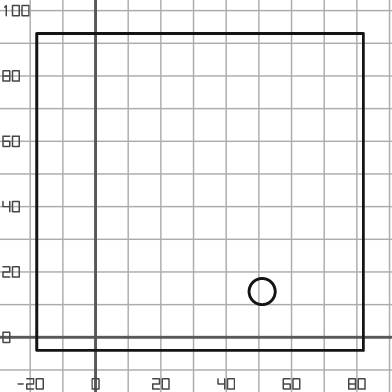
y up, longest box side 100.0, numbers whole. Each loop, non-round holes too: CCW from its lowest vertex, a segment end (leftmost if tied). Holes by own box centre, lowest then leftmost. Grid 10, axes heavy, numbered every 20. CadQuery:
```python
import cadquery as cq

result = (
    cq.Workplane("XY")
    .moveTo(-18.0, -4.0)
    .lineTo(82.0, -4.0)
    .lineTo(82.0, 93.0)
    .lineTo(-18.0, 93.0)
    .close()
    .moveTo(51.0, 14.0)
    .circle(4.0)
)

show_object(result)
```